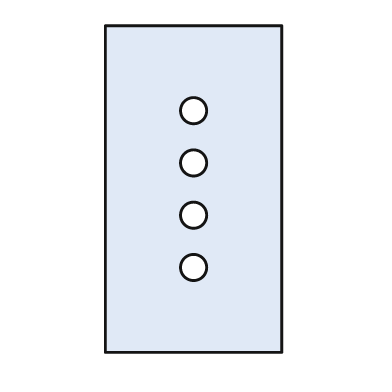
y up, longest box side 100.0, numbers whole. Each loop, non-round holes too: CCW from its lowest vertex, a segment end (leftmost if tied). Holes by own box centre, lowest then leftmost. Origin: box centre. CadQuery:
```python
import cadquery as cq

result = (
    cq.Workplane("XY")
    .moveTo(-27.0, -50.0)
    .lineTo(27.0, -50.0)
    .lineTo(27.0, 50.0)
    .lineTo(-27.0, 50.0)
    .close()
    .moveTo(0.0, -24.0)
    .circle(4.0)
    .moveTo(0.0, -8.0)
    .circle(4.0)
    .moveTo(0.0, 8.0)
    .circle(4.0)
    .moveTo(0.0, 24.0)
    .circle(4.0)
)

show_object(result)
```